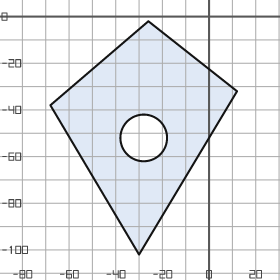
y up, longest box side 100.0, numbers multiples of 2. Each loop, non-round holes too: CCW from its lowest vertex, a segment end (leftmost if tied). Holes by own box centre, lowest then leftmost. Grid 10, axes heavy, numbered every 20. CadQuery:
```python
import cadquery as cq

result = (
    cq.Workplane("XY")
    .moveTo(-30.0, -102.0)
    .lineTo(12.0, -32.0)
    .lineTo(-26.0, -2.0)
    .lineTo(-68.0, -38.0)
    .close()
    .moveTo(-28.0, -52.0)
    .circle(10.0)
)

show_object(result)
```